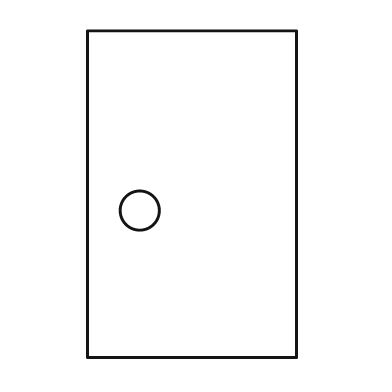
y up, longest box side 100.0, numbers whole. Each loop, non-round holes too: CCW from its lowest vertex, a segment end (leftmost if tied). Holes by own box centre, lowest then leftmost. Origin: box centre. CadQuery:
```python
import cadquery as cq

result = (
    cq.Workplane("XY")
    .moveTo(-32.0, -50.0)
    .lineTo(32.0, -50.0)
    .lineTo(32.0, 50.0)
    .lineTo(-32.0, 50.0)
    .close()
    .moveTo(-16.0, -5.0)
    .circle(6.0)
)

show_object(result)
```